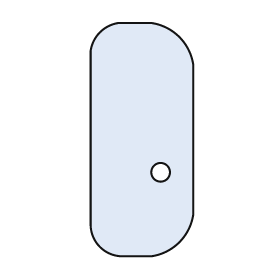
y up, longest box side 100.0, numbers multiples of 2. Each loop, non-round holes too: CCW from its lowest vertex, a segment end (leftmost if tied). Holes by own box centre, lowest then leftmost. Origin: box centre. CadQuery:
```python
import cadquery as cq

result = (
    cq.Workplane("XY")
    .moveTo(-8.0, -50.0)
    .lineTo(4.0, -50.0)
    .threePointArc((16.0, -44.0), (22.0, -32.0))
    .lineTo(22.0, 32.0)
    .threePointArc((16.0, 44.0), (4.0, 50.0))
    .lineTo(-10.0, 50.0)
    .threePointArc((-18.0, 46.0), (-22.0, 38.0))
    .lineTo(-22.0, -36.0)
    .threePointArc((-18.0, -46.0), (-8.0, -50.0))
    .close()
    .moveTo(8.0, -14.0)
    .circle(4.0)
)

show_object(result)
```